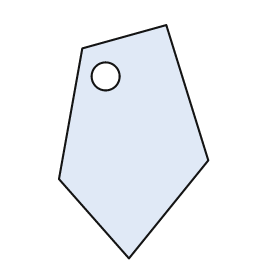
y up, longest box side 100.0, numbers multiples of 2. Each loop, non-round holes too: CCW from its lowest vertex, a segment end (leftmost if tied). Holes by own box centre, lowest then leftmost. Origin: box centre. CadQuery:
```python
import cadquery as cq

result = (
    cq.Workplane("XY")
    .moveTo(-2.0, -50.0)
    .lineTo(32.0, -8.0)
    .lineTo(14.0, 50.0)
    .lineTo(-22.0, 40.0)
    .lineTo(-32.0, -16.0)
    .close()
    .moveTo(-12.0, 28.0)
    .circle(6.0)
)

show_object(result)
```